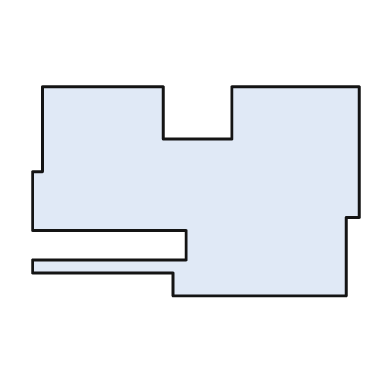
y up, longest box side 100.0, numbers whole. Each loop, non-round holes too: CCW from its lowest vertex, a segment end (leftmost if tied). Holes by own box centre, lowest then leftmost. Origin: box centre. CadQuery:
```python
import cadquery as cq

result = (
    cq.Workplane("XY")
    .moveTo(-7.0, -32.0)
    .lineTo(46.0, -32.0)
    .lineTo(46.0, -8.0)
    .lineTo(50.0, -8.0)
    .lineTo(50.0, 32.0)
    .lineTo(11.0, 32.0)
    .lineTo(11.0, 16.0)
    .lineTo(-10.0, 16.0)
    .lineTo(-10.0, 32.0)
    .lineTo(-47.0, 32.0)
    .lineTo(-47.0, 6.0)
    .lineTo(-50.0, 6.0)
    .lineTo(-50.0, -12.0)
    .lineTo(-3.0, -12.0)
    .lineTo(-3.0, -21.0)
    .lineTo(-50.0, -21.0)
    .lineTo(-50.0, -25.0)
    .lineTo(-7.0, -25.0)
    .close()
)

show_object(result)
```